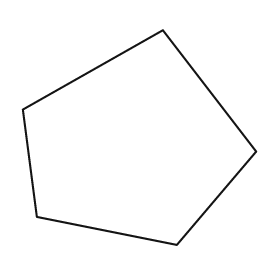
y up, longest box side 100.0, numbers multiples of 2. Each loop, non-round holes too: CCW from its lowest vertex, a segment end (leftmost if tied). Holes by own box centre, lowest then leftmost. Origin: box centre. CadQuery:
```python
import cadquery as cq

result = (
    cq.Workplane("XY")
    .moveTo(16.0, -46.0)
    .lineTo(50.0, -6.0)
    .lineTo(10.0, 46.0)
    .lineTo(-50.0, 12.0)
    .lineTo(-44.0, -34.0)
    .close()
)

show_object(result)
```